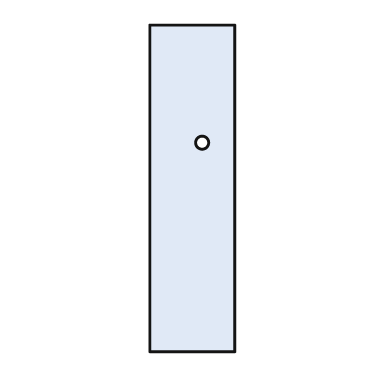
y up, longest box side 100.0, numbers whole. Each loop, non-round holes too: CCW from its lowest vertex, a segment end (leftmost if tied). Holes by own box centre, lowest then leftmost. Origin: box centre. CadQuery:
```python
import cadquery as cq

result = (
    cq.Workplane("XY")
    .moveTo(-13.0, -50.0)
    .lineTo(13.0, -50.0)
    .lineTo(13.0, 50.0)
    .lineTo(-13.0, 50.0)
    .close()
    .moveTo(3.0, 14.0)
    .circle(2.0)
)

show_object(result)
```